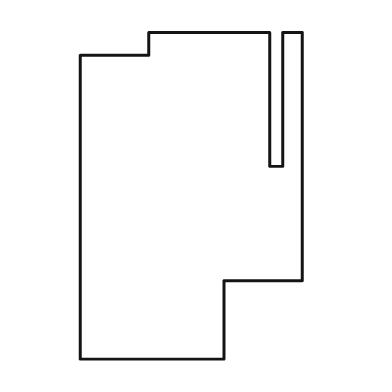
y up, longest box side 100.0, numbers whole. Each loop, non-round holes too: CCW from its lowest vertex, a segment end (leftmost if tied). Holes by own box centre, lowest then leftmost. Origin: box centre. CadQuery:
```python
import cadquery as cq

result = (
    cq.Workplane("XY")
    .moveTo(-34.0, -50.0)
    .lineTo(10.0, -50.0)
    .lineTo(10.0, -26.0)
    .lineTo(34.0, -26.0)
    .lineTo(34.0, 50.0)
    .lineTo(28.0, 50.0)
    .lineTo(28.0, 9.0)
    .lineTo(24.0, 9.0)
    .lineTo(24.0, 50.0)
    .lineTo(-13.0, 50.0)
    .lineTo(-13.0, 43.0)
    .lineTo(-34.0, 43.0)
    .close()
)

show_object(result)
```